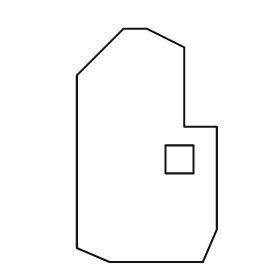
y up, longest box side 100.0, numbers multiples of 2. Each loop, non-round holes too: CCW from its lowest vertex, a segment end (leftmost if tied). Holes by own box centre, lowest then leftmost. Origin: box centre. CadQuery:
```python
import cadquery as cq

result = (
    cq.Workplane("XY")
    .moveTo(-16.0, -50.0)
    .lineTo(24.0, -50.0)
    .lineTo(30.0, -36.0)
    .lineTo(30.0, 8.0)
    .lineTo(16.0, 8.0)
    .lineTo(16.0, 42.0)
    .lineTo(0.0, 50.0)
    .lineTo(-10.0, 50.0)
    .lineTo(-30.0, 30.0)
    .lineTo(-30.0, -44.0)
    .close()
    .moveTo(8.0, -12.0)
    .lineTo(20.0, -12.0)
    .lineTo(20.0, 0.0)
    .lineTo(8.0, 0.0)
    .close()
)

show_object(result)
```